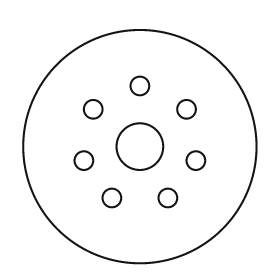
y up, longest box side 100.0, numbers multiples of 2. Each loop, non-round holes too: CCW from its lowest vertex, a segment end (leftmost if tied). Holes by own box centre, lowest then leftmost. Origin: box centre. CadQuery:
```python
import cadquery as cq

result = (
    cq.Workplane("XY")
    .moveTo(0.0, 0.0)
    .circle(50.0)
    .moveTo(-12.0, -22.0)
    .circle(4.0)
    .moveTo(12.0, -22.0)
    .circle(4.0)
    .moveTo(-24.0, -6.0)
    .circle(4.0)
    .moveTo(24.0, -6.0)
    .circle(4.0)
    .moveTo(0.0, 0.0)
    .circle(10.0)
    .moveTo(-20.0, 16.0)
    .circle(4.0)
    .moveTo(20.0, 16.0)
    .circle(4.0)
    .moveTo(0.0, 26.0)
    .circle(4.0)
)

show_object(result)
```